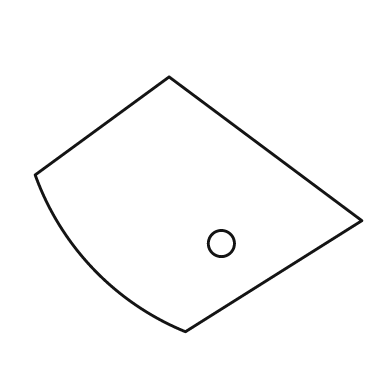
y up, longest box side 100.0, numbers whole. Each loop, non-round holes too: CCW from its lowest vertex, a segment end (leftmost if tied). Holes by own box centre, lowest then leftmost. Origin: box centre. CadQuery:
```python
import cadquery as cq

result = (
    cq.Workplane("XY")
    .moveTo(-4.0, -39.0)
    .lineTo(50.0, -5.0)
    .lineTo(-9.0, 39.0)
    .lineTo(-50.0, 9.0)
    .threePointArc((-32.0, -20.0), (-4.0, -39.0))
    .close()
    .moveTo(7.0, -12.0)
    .circle(4.0)
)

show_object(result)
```